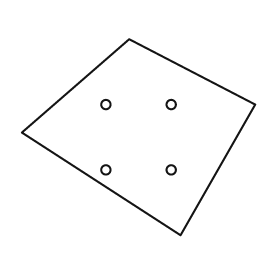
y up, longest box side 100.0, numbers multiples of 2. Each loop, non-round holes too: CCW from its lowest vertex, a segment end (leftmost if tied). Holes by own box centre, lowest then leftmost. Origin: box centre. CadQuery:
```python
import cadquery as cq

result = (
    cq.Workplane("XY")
    .moveTo(18.0, -42.0)
    .lineTo(50.0, 14.0)
    .lineTo(-4.0, 42.0)
    .lineTo(-50.0, 2.0)
    .close()
    .moveTo(-14.0, -14.0)
    .circle(2.0)
    .moveTo(14.0, -14.0)
    .circle(2.0)
    .moveTo(-14.0, 14.0)
    .circle(2.0)
    .moveTo(14.0, 14.0)
    .circle(2.0)
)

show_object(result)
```